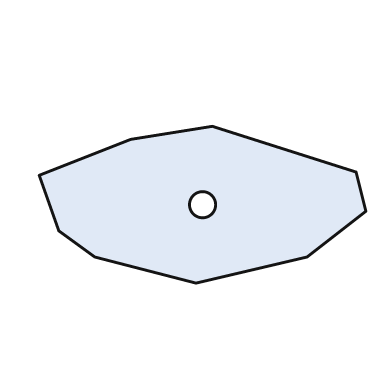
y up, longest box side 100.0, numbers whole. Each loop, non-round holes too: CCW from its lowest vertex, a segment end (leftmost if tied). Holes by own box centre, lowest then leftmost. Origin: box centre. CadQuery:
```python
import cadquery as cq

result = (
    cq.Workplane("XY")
    .moveTo(-2.0, -24.0)
    .lineTo(32.0, -16.0)
    .lineTo(50.0, -2.0)
    .lineTo(47.0, 10.0)
    .lineTo(3.0, 24.0)
    .lineTo(-22.0, 20.0)
    .lineTo(-50.0, 9.0)
    .lineTo(-44.0, -8.0)
    .lineTo(-33.0, -16.0)
    .close()
    .moveTo(0.0, 0.0)
    .circle(4.0)
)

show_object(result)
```